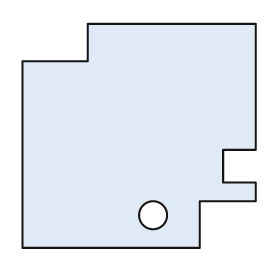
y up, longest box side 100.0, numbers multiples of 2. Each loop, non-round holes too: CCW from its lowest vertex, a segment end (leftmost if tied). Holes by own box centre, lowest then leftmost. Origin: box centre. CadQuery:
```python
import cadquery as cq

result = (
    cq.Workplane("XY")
    .moveTo(-50.0, -48.0)
    .lineTo(26.0, -48.0)
    .lineTo(26.0, -28.0)
    .lineTo(50.0, -28.0)
    .lineTo(50.0, -20.0)
    .lineTo(36.0, -20.0)
    .lineTo(36.0, -6.0)
    .lineTo(50.0, -6.0)
    .lineTo(50.0, 48.0)
    .lineTo(-22.0, 48.0)
    .lineTo(-22.0, 32.0)
    .lineTo(-50.0, 32.0)
    .close()
    .moveTo(6.0, -34.0)
    .circle(6.0)
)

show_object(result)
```